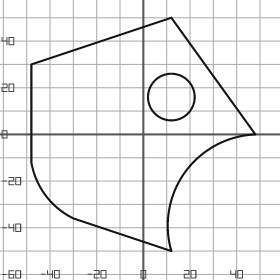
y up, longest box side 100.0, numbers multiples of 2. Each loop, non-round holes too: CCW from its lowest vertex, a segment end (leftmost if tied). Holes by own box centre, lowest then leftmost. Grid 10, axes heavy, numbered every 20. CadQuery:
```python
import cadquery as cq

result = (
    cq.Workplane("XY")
    .moveTo(12.0, -50.0)
    .threePointArc((18.0, -16.0), (48.0, 0.0))
    .lineTo(12.0, 50.0)
    .lineTo(-48.0, 30.0)
    .lineTo(-48.0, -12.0)
    .threePointArc((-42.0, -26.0), (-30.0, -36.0))
    .close()
    .moveTo(12.0, 16.0)
    .circle(10.0)
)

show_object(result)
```